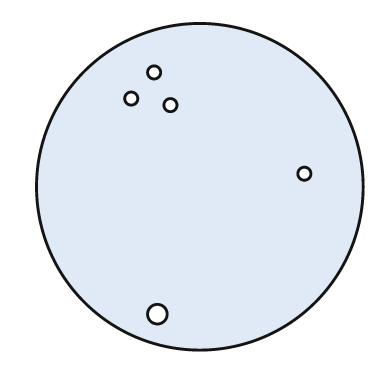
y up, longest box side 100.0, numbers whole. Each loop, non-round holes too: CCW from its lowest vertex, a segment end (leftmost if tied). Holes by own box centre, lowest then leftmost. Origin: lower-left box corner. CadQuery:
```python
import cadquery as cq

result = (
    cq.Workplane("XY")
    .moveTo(50.0, 50.0)
    .circle(50.0)
    .moveTo(37.0, 11.0)
    .circle(3.0)
    .moveTo(82.0, 54.0)
    .circle(2.0)
    .moveTo(41.0, 75.0)
    .circle(2.0)
    .moveTo(29.0, 77.0)
    .circle(2.0)
    .moveTo(36.0, 85.0)
    .circle(2.0)
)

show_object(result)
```